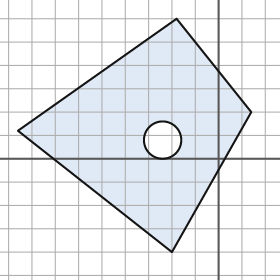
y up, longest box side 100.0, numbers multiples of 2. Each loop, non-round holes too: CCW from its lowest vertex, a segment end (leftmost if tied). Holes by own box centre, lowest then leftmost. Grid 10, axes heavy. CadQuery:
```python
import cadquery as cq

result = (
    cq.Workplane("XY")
    .moveTo(-20.0, -40.0)
    .lineTo(14.0, 20.0)
    .lineTo(-18.0, 60.0)
    .lineTo(-86.0, 12.0)
    .close()
    .moveTo(-24.0, 8.0)
    .circle(8.0)
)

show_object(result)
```